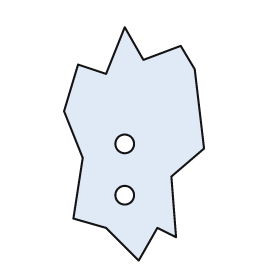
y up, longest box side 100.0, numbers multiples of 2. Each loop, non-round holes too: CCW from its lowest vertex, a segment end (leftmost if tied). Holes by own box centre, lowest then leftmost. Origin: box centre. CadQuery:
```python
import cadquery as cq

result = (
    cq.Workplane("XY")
    .moveTo(2.0, -50.0)
    .lineTo(10.0, -36.0)
    .lineTo(18.0, -40.0)
    .lineTo(16.0, -14.0)
    .lineTo(30.0, -2.0)
    .lineTo(26.0, 32.0)
    .lineTo(20.0, 42.0)
    .lineTo(4.0, 36.0)
    .lineTo(-4.0, 50.0)
    .lineTo(-12.0, 30.0)
    .lineTo(-24.0, 34.0)
    .lineTo(-30.0, 14.0)
    .lineTo(-22.0, -6.0)
    .lineTo(-26.0, -32.0)
    .lineTo(-12.0, -36.0)
    .close()
    .moveTo(-4.0, -22.0)
    .circle(4.0)
    .moveTo(-4.0, 0.0)
    .circle(4.0)
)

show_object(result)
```